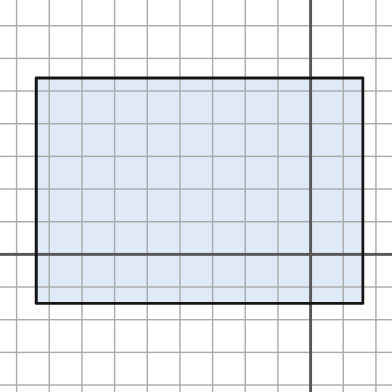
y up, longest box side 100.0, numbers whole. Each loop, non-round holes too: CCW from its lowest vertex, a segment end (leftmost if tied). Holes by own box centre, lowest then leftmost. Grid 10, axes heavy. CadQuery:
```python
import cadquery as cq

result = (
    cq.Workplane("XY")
    .moveTo(-84.0, -15.0)
    .lineTo(16.0, -15.0)
    .lineTo(16.0, 54.0)
    .lineTo(-84.0, 54.0)
    .close()
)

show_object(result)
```